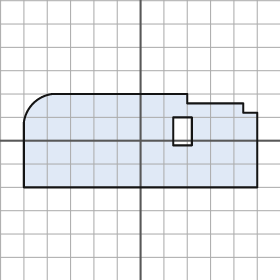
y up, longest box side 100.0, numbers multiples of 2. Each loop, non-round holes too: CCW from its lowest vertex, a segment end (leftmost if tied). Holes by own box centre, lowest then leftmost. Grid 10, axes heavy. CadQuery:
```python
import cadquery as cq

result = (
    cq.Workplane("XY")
    .moveTo(-50.0, -20.0)
    .lineTo(50.0, -20.0)
    .lineTo(50.0, 12.0)
    .lineTo(44.0, 12.0)
    .lineTo(44.0, 16.0)
    .lineTo(20.0, 16.0)
    .lineTo(20.0, 20.0)
    .lineTo(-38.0, 20.0)
    .threePointArc((-46.0, 16.0), (-50.0, 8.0))
    .close()
    .moveTo(14.0, -2.0)
    .lineTo(22.0, -2.0)
    .lineTo(22.0, 10.0)
    .lineTo(14.0, 10.0)
    .close()
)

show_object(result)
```